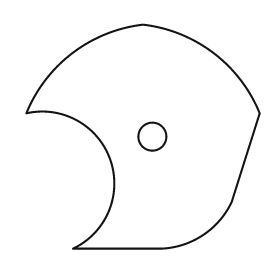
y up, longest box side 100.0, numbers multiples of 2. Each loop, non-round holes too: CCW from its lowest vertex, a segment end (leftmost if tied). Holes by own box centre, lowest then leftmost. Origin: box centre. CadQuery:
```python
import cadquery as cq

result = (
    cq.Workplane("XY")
    .moveTo(-30.0, -48.0)
    .lineTo(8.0, -48.0)
    .threePointArc((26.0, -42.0), (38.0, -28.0))
    .lineTo(50.0, 10.0)
    .threePointArc((30.0, 36.0), (0.0, 48.0))
    .threePointArc((-30.0, 36.0), (-50.0, 10.0))
    .threePointArc((-14.0, -10.0), (-30.0, -48.0))
    .close()
    .moveTo(4.0, 0.0)
    .circle(6.0)
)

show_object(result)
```